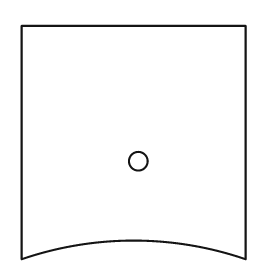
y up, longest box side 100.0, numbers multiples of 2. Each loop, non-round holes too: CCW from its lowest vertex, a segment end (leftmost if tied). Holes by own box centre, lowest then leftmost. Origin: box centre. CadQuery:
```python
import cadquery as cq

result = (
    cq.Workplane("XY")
    .moveTo(-48.0, -50.0)
    .threePointArc((0.0, -42.0), (48.0, -50.0))
    .lineTo(48.0, 50.0)
    .lineTo(-48.0, 50.0)
    .close()
    .moveTo(2.0, -8.0)
    .circle(4.0)
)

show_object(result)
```